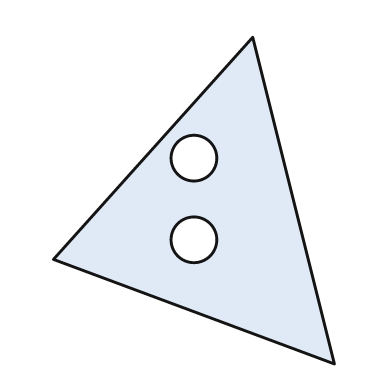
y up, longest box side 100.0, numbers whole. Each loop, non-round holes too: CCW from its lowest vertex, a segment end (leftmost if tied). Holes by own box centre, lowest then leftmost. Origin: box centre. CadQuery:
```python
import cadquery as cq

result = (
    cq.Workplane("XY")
    .moveTo(43.0, -50.0)
    .lineTo(18.0, 50.0)
    .lineTo(-43.0, -18.0)
    .close()
    .moveTo(0.0, -12.0)
    .circle(7.0)
    .moveTo(0.0, 13.0)
    .circle(7.0)
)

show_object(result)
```